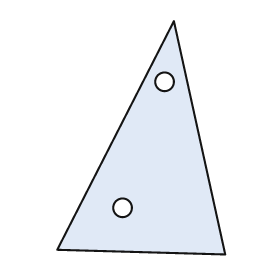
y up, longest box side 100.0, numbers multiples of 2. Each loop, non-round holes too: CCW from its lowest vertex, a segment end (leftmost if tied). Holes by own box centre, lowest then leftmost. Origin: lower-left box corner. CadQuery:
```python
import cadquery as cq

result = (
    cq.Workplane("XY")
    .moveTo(72.0, 0.0)
    .lineTo(50.0, 100.0)
    .lineTo(0.0, 2.0)
    .close()
    .moveTo(28.0, 20.0)
    .circle(4.0)
    .moveTo(46.0, 74.0)
    .circle(4.0)
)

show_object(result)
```